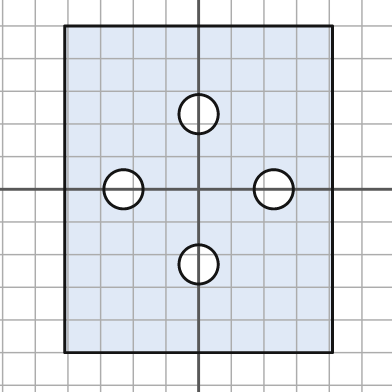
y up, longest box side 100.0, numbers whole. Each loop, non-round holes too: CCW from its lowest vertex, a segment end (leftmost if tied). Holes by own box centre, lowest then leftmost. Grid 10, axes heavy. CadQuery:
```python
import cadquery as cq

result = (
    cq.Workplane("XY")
    .moveTo(-41.0, -50.0)
    .lineTo(41.0, -50.0)
    .lineTo(41.0, 50.0)
    .lineTo(-41.0, 50.0)
    .close()
    .moveTo(0.0, -23.0)
    .circle(6.0)
    .moveTo(-23.0, 0.0)
    .circle(6.0)
    .moveTo(23.0, 0.0)
    .circle(6.0)
    .moveTo(0.0, 23.0)
    .circle(6.0)
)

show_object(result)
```